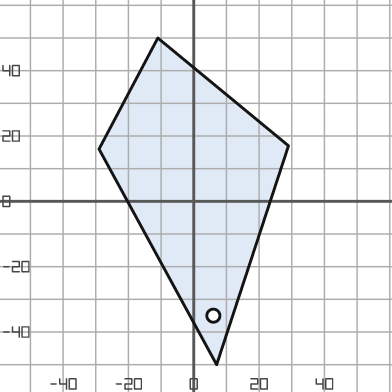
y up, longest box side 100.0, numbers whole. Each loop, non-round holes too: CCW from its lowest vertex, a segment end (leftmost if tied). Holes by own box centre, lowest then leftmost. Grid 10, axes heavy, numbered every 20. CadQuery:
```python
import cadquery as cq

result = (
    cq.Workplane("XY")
    .moveTo(7.0, -50.0)
    .lineTo(29.0, 17.0)
    .lineTo(-11.0, 50.0)
    .lineTo(-29.0, 16.0)
    .close()
    .moveTo(6.0, -35.0)
    .circle(2.0)
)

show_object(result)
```